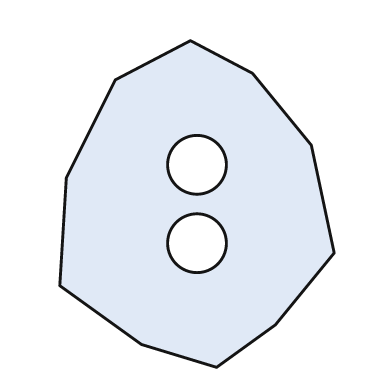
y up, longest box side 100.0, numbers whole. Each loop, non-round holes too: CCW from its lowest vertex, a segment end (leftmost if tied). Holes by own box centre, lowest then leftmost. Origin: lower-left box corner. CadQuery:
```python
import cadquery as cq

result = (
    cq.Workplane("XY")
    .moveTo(48.0, 0.0)
    .lineTo(66.0, 13.0)
    .lineTo(84.0, 35.0)
    .lineTo(77.0, 68.0)
    .lineTo(59.0, 90.0)
    .lineTo(40.0, 100.0)
    .lineTo(17.0, 88.0)
    .lineTo(2.0, 58.0)
    .lineTo(0.0, 25.0)
    .lineTo(25.0, 7.0)
    .close()
    .moveTo(42.0, 38.0)
    .circle(9.0)
    .moveTo(42.0, 62.0)
    .circle(9.0)
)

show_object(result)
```